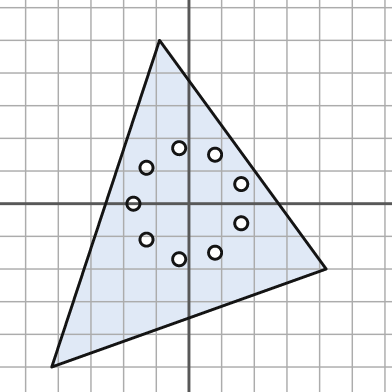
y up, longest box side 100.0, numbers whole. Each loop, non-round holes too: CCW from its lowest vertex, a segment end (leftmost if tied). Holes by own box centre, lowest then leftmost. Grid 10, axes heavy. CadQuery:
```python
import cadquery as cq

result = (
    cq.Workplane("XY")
    .moveTo(-42.0, -50.0)
    .lineTo(42.0, -20.0)
    .lineTo(-9.0, 50.0)
    .close()
    .moveTo(-3.0, -17.0)
    .circle(2.0)
    .moveTo(8.0, -15.0)
    .circle(2.0)
    .moveTo(-13.0, -11.0)
    .circle(2.0)
    .moveTo(16.0, -6.0)
    .circle(2.0)
    .moveTo(-17.0, 0.0)
    .circle(2.0)
    .moveTo(16.0, 6.0)
    .circle(2.0)
    .moveTo(-13.0, 11.0)
    .circle(2.0)
    .moveTo(8.0, 15.0)
    .circle(2.0)
    .moveTo(-3.0, 17.0)
    .circle(2.0)
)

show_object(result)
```